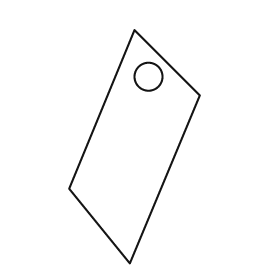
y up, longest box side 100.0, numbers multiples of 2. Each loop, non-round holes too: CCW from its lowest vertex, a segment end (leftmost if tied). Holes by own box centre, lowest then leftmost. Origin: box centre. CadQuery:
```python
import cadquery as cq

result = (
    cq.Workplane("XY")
    .moveTo(-2.0, -50.0)
    .lineTo(28.0, 22.0)
    .lineTo(0.0, 50.0)
    .lineTo(-28.0, -18.0)
    .close()
    .moveTo(6.0, 30.0)
    .circle(6.0)
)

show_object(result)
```